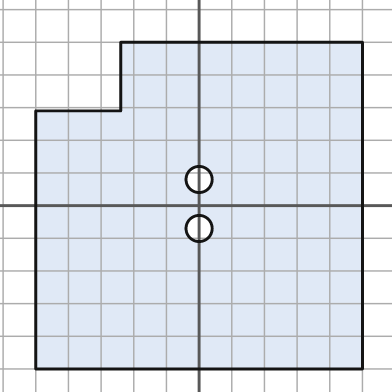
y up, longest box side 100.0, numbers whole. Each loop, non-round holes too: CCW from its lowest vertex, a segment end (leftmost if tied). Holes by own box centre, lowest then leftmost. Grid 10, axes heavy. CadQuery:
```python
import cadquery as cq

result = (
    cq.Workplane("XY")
    .moveTo(-50.0, -50.0)
    .lineTo(50.0, -50.0)
    .lineTo(50.0, 50.0)
    .lineTo(-24.0, 50.0)
    .lineTo(-24.0, 29.0)
    .lineTo(-50.0, 29.0)
    .close()
    .moveTo(0.0, -7.0)
    .circle(4.0)
    .moveTo(0.0, 8.0)
    .circle(4.0)
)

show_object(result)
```